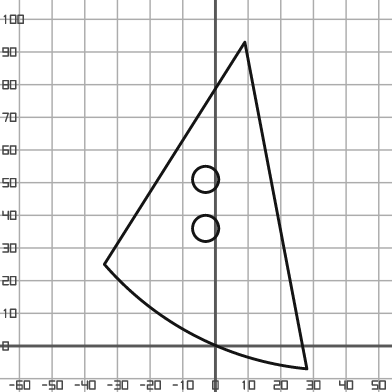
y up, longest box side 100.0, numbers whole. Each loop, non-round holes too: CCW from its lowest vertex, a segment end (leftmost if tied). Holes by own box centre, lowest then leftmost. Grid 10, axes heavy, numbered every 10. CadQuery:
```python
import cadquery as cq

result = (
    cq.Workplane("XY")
    .moveTo(28.0, -7.0)
    .lineTo(9.0, 93.0)
    .lineTo(-34.0, 25.0)
    .threePointArc((-6.0, 3.0), (28.0, -7.0))
    .close()
    .moveTo(-3.0, 36.0)
    .circle(4.0)
    .moveTo(-3.0, 51.0)
    .circle(4.0)
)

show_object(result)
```